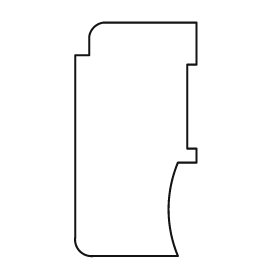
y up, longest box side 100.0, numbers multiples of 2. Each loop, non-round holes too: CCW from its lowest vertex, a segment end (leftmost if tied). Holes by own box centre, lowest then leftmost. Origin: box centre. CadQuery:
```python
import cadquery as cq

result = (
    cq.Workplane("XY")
    .moveTo(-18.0, -50.0)
    .lineTo(18.0, -50.0)
    .threePointArc((14.0, -30.0), (18.0, -10.0))
    .lineTo(26.0, -10.0)
    .lineTo(26.0, -4.0)
    .lineTo(22.0, -4.0)
    .lineTo(22.0, 32.0)
    .lineTo(26.0, 32.0)
    .lineTo(26.0, 50.0)
    .lineTo(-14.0, 50.0)
    .threePointArc((-18.0, 48.0), (-20.0, 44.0))
    .lineTo(-20.0, 36.0)
    .lineTo(-26.0, 36.0)
    .lineTo(-26.0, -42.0)
    .threePointArc((-24.0, -48.0), (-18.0, -50.0))
    .close()
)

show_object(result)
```